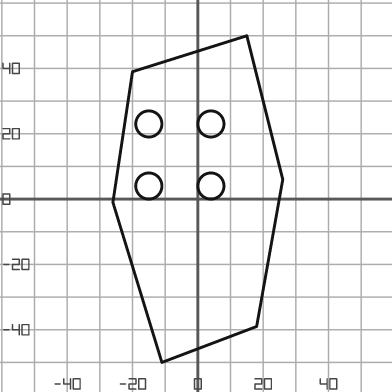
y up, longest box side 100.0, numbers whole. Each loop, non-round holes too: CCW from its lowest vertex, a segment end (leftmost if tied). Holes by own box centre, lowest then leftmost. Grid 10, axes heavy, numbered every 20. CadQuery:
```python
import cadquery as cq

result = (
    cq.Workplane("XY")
    .moveTo(-11.0, -50.0)
    .lineTo(18.0, -39.0)
    .lineTo(26.0, 6.0)
    .lineTo(15.0, 50.0)
    .lineTo(-20.0, 39.0)
    .lineTo(-26.0, -1.0)
    .close()
    .moveTo(-15.0, 4.0)
    .circle(4.0)
    .moveTo(4.0, 4.0)
    .circle(4.0)
    .moveTo(-15.0, 23.0)
    .circle(4.0)
    .moveTo(4.0, 23.0)
    .circle(4.0)
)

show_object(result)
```